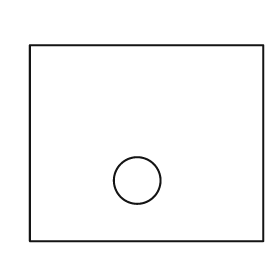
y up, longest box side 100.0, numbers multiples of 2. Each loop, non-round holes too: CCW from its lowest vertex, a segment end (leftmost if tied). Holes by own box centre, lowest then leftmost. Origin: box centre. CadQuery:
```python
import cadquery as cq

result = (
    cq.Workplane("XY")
    .moveTo(-50.0, -42.0)
    .lineTo(50.0, -42.0)
    .lineTo(50.0, 42.0)
    .lineTo(-50.0, 42.0)
    .close()
    .moveTo(-4.0, -16.0)
    .circle(10.0)
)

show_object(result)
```